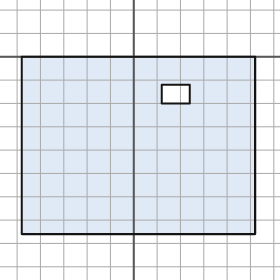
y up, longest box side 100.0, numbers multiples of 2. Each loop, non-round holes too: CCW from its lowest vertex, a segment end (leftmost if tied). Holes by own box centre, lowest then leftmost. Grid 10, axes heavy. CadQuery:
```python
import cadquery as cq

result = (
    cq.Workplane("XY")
    .moveTo(-48.0, -76.0)
    .lineTo(52.0, -76.0)
    .lineTo(52.0, 0.0)
    .lineTo(-48.0, 0.0)
    .close()
    .moveTo(12.0, -20.0)
    .lineTo(24.0, -20.0)
    .lineTo(24.0, -12.0)
    .lineTo(12.0, -12.0)
    .close()
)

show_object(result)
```